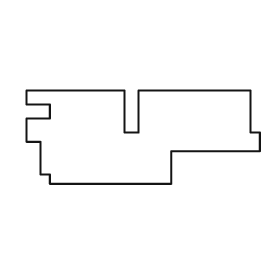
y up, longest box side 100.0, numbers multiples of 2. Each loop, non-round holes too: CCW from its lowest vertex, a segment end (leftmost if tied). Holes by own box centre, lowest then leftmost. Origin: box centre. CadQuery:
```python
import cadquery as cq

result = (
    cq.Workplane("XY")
    .moveTo(-40.0, -20.0)
    .lineTo(12.0, -20.0)
    .lineTo(12.0, -6.0)
    .lineTo(50.0, -6.0)
    .lineTo(50.0, 2.0)
    .lineTo(46.0, 2.0)
    .lineTo(46.0, 20.0)
    .lineTo(-2.0, 20.0)
    .lineTo(-2.0, 2.0)
    .lineTo(-8.0, 2.0)
    .lineTo(-8.0, 20.0)
    .lineTo(-50.0, 20.0)
    .lineTo(-50.0, 14.0)
    .lineTo(-40.0, 14.0)
    .lineTo(-40.0, 8.0)
    .lineTo(-50.0, 8.0)
    .lineTo(-50.0, -2.0)
    .lineTo(-44.0, -2.0)
    .lineTo(-44.0, -16.0)
    .lineTo(-40.0, -16.0)
    .close()
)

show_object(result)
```